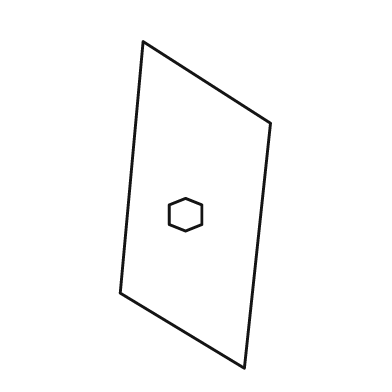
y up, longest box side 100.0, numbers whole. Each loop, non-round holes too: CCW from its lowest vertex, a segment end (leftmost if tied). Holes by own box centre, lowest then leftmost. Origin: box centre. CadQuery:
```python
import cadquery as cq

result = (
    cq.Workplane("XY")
    .moveTo(15.0, -50.0)
    .lineTo(23.0, 25.0)
    .lineTo(-16.0, 50.0)
    .lineTo(-23.0, -27.0)
    .close()
    .moveTo(-3.0, -8.0)
    .lineTo(2.0, -6.0)
    .lineTo(2.0, 0.0)
    .lineTo(-3.0, 2.0)
    .lineTo(-8.0, 0.0)
    .lineTo(-8.0, -6.0)
    .close()
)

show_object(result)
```